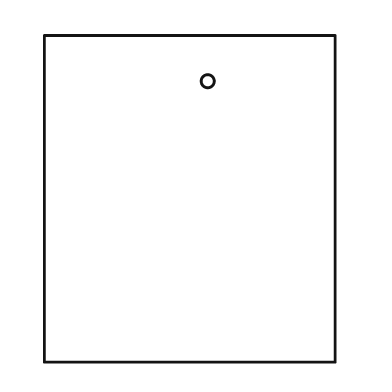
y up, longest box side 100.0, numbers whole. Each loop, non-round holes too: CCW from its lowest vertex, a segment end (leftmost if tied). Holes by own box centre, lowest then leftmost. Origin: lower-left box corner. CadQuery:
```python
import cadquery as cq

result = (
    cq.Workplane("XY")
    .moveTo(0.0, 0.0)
    .lineTo(89.0, 0.0)
    .lineTo(89.0, 100.0)
    .lineTo(0.0, 100.0)
    .close()
    .moveTo(50.0, 86.0)
    .circle(2.0)
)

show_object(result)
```